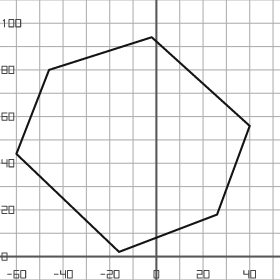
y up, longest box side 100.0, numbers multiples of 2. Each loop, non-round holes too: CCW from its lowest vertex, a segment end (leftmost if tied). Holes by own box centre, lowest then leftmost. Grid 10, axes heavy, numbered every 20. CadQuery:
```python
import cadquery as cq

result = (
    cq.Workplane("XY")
    .moveTo(-16.0, 2.0)
    .lineTo(26.0, 18.0)
    .lineTo(40.0, 56.0)
    .lineTo(-2.0, 94.0)
    .lineTo(-46.0, 80.0)
    .lineTo(-60.0, 44.0)
    .close()
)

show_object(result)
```